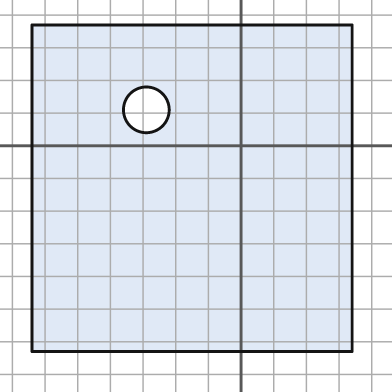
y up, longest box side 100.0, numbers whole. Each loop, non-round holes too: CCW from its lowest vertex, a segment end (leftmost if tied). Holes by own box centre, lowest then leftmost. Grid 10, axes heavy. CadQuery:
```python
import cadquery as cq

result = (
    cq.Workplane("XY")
    .moveTo(-64.0, -63.0)
    .lineTo(34.0, -63.0)
    .lineTo(34.0, 37.0)
    .lineTo(-64.0, 37.0)
    .close()
    .moveTo(-29.0, 11.0)
    .circle(7.0)
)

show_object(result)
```